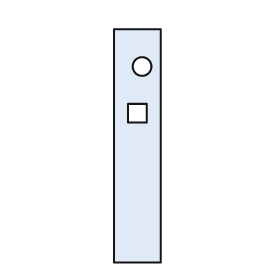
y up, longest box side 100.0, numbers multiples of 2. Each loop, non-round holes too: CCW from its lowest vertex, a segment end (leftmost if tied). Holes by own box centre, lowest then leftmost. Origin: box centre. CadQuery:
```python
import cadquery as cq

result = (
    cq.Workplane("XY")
    .moveTo(-10.0, -50.0)
    .lineTo(10.0, -50.0)
    .lineTo(10.0, 50.0)
    .lineTo(-10.0, 50.0)
    .close()
    .moveTo(-4.0, 10.0)
    .lineTo(4.0, 10.0)
    .lineTo(4.0, 18.0)
    .lineTo(-4.0, 18.0)
    .close()
    .moveTo(2.0, 34.0)
    .circle(4.0)
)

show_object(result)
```